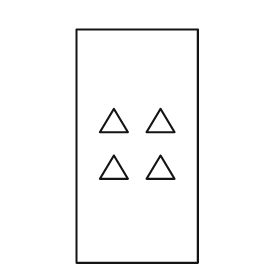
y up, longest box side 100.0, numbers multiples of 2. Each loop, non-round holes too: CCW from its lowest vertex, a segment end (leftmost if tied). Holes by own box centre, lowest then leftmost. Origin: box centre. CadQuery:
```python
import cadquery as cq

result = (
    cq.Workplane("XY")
    .moveTo(-26.0, -50.0)
    .lineTo(26.0, -50.0)
    .lineTo(26.0, 50.0)
    .lineTo(-26.0, 50.0)
    .close()
    .moveTo(-16.0, -14.0)
    .lineTo(-4.0, -14.0)
    .lineTo(-10.0, -4.0)
    .close()
    .moveTo(4.0, -14.0)
    .lineTo(16.0, -14.0)
    .lineTo(10.0, -4.0)
    .close()
    .moveTo(-16.0, 6.0)
    .lineTo(-4.0, 6.0)
    .lineTo(-10.0, 16.0)
    .close()
    .moveTo(4.0, 6.0)
    .lineTo(16.0, 6.0)
    .lineTo(10.0, 16.0)
    .close()
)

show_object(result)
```